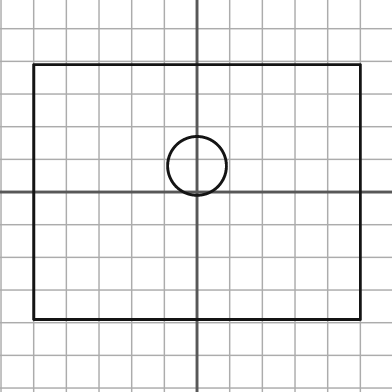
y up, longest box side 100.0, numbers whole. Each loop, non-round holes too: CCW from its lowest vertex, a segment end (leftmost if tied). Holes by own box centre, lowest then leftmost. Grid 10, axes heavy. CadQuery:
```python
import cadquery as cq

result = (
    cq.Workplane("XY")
    .moveTo(-50.0, -39.0)
    .lineTo(50.0, -39.0)
    .lineTo(50.0, 39.0)
    .lineTo(-50.0, 39.0)
    .close()
    .moveTo(0.0, 8.0)
    .circle(9.0)
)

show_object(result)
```